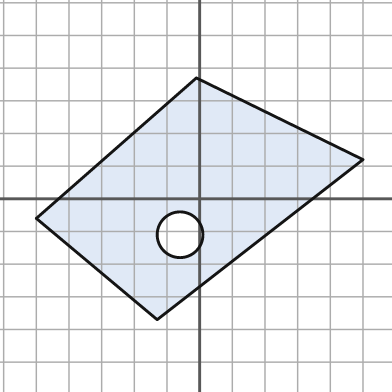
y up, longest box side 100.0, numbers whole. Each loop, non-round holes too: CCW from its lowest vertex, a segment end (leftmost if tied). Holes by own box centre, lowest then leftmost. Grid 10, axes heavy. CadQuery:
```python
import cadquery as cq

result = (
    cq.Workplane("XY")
    .moveTo(-13.0, -37.0)
    .lineTo(50.0, 12.0)
    .lineTo(-1.0, 37.0)
    .lineTo(-50.0, -6.0)
    .close()
    .moveTo(-6.0, -11.0)
    .circle(7.0)
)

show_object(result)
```